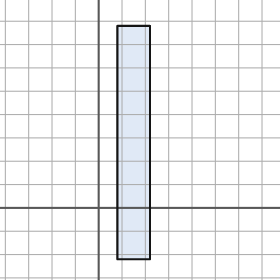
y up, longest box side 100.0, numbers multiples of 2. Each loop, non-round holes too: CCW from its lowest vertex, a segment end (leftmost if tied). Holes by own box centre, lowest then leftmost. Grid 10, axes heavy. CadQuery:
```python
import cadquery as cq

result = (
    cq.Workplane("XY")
    .moveTo(8.0, -22.0)
    .lineTo(22.0, -22.0)
    .lineTo(22.0, 78.0)
    .lineTo(8.0, 78.0)
    .close()
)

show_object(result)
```